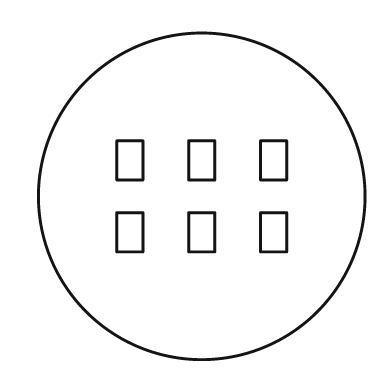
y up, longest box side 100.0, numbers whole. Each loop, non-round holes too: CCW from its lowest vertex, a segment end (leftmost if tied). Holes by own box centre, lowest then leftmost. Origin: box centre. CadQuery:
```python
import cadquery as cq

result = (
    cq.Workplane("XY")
    .moveTo(0.0, 0.0)
    .circle(50.0)
    .moveTo(-26.0, -17.0)
    .lineTo(-18.0, -17.0)
    .lineTo(-18.0, -5.0)
    .lineTo(-26.0, -5.0)
    .close()
    .moveTo(-4.0, -17.0)
    .lineTo(4.0, -17.0)
    .lineTo(4.0, -5.0)
    .lineTo(-4.0, -5.0)
    .close()
    .moveTo(18.0, -17.0)
    .lineTo(26.0, -17.0)
    .lineTo(26.0, -5.0)
    .lineTo(18.0, -5.0)
    .close()
    .moveTo(-26.0, 5.0)
    .lineTo(-18.0, 5.0)
    .lineTo(-18.0, 17.0)
    .lineTo(-26.0, 17.0)
    .close()
    .moveTo(-4.0, 5.0)
    .lineTo(4.0, 5.0)
    .lineTo(4.0, 17.0)
    .lineTo(-4.0, 17.0)
    .close()
    .moveTo(18.0, 5.0)
    .lineTo(26.0, 5.0)
    .lineTo(26.0, 17.0)
    .lineTo(18.0, 17.0)
    .close()
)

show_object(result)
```